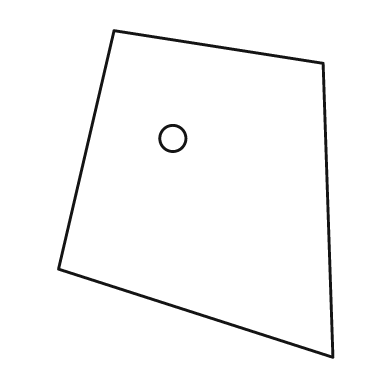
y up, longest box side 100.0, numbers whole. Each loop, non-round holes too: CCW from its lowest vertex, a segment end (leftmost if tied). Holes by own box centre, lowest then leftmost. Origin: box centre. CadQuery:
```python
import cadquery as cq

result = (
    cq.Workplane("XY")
    .moveTo(42.0, -50.0)
    .lineTo(39.0, 40.0)
    .lineTo(-25.0, 50.0)
    .lineTo(-42.0, -23.0)
    .close()
    .moveTo(-7.0, 17.0)
    .circle(4.0)
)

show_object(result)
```